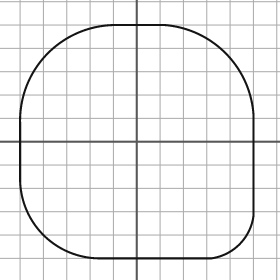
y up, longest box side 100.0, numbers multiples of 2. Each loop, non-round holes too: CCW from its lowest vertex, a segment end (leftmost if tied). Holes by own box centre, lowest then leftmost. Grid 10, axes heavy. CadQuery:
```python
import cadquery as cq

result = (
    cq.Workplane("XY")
    .moveTo(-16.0, -50.0)
    .lineTo(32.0, -50.0)
    .threePointArc((44.0, -44.0), (50.0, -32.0))
    .lineTo(50.0, 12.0)
    .threePointArc((38.0, 38.0), (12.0, 50.0))
    .lineTo(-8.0, 50.0)
    .threePointArc((-38.0, 38.0), (-50.0, 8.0))
    .lineTo(-50.0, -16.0)
    .threePointArc((-40.0, -40.0), (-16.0, -50.0))
    .close()
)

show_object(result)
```